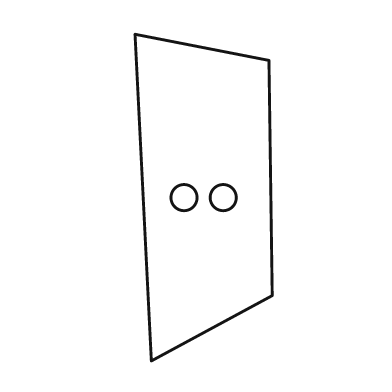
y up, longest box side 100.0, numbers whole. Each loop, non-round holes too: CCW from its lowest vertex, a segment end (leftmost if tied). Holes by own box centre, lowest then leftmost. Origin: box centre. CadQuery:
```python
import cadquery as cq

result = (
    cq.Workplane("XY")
    .moveTo(-16.0, -50.0)
    .lineTo(21.0, -30.0)
    .lineTo(20.0, 42.0)
    .lineTo(-21.0, 50.0)
    .close()
    .moveTo(-6.0, 0.0)
    .circle(4.0)
    .moveTo(6.0, 0.0)
    .circle(4.0)
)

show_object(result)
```